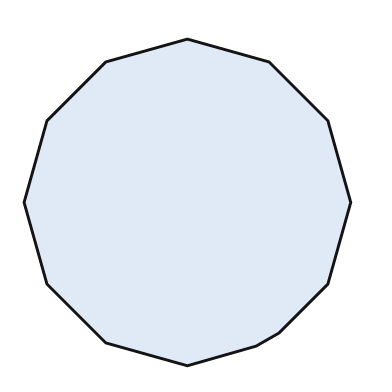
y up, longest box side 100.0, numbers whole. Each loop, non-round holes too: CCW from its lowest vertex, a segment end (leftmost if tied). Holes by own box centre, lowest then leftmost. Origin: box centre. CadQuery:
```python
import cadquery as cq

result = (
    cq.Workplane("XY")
    .moveTo(0.0, -50.0)
    .lineTo(21.0, -44.0)
    .lineTo(28.0, -40.0)
    .lineTo(43.0, -25.0)
    .lineTo(50.0, 0.0)
    .lineTo(43.0, 25.0)
    .lineTo(25.0, 43.0)
    .lineTo(0.0, 50.0)
    .lineTo(-25.0, 43.0)
    .lineTo(-43.0, 25.0)
    .lineTo(-50.0, 0.0)
    .lineTo(-43.0, -25.0)
    .lineTo(-25.0, -43.0)
    .close()
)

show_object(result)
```